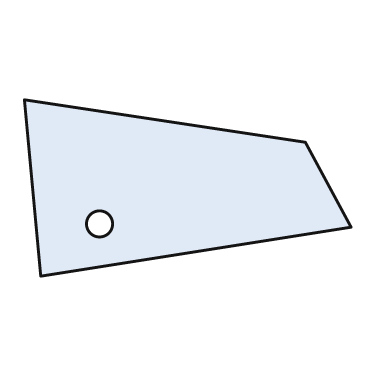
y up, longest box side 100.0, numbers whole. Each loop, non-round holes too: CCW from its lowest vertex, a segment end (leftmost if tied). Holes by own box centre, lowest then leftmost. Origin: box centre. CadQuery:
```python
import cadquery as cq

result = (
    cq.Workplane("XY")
    .moveTo(-45.0, -27.0)
    .lineTo(50.0, -12.0)
    .lineTo(36.0, 14.0)
    .lineTo(-50.0, 27.0)
    .close()
    .moveTo(-27.0, -11.0)
    .circle(4.0)
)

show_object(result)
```